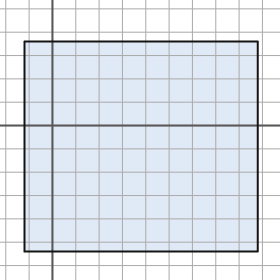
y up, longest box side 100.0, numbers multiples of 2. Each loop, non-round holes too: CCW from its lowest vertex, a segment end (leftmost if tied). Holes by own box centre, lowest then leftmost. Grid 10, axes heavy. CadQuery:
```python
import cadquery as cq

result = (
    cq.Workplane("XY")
    .moveTo(-12.0, -54.0)
    .lineTo(88.0, -54.0)
    .lineTo(88.0, 36.0)
    .lineTo(-12.0, 36.0)
    .close()
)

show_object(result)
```